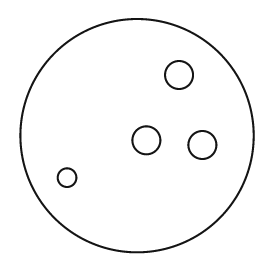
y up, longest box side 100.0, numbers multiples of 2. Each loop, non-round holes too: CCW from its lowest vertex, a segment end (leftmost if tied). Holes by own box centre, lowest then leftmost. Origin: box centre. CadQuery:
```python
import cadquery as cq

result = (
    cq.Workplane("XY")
    .moveTo(0.0, 0.0)
    .circle(50.0)
    .moveTo(-30.0, -18.0)
    .circle(4.0)
    .moveTo(28.0, -4.0)
    .circle(6.0)
    .moveTo(4.0, -2.0)
    .circle(6.0)
    .moveTo(18.0, 26.0)
    .circle(6.0)
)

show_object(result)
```